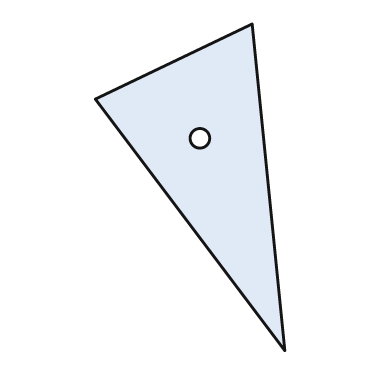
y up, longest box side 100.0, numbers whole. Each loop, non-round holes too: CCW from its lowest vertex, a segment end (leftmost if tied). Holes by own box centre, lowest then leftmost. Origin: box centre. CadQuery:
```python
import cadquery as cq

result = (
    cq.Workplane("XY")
    .moveTo(29.0, -50.0)
    .lineTo(19.0, 50.0)
    .lineTo(-29.0, 27.0)
    .close()
    .moveTo(3.0, 15.0)
    .circle(3.0)
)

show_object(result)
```